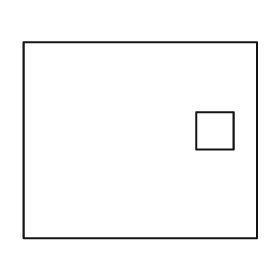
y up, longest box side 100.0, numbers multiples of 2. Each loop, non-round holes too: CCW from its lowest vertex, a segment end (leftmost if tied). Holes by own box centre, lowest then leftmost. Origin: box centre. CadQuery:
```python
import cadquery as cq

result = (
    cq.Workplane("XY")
    .moveTo(-50.0, -42.0)
    .lineTo(50.0, -42.0)
    .lineTo(50.0, 42.0)
    .lineTo(-50.0, 42.0)
    .close()
    .moveTo(24.0, -4.0)
    .lineTo(40.0, -4.0)
    .lineTo(40.0, 12.0)
    .lineTo(24.0, 12.0)
    .close()
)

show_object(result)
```